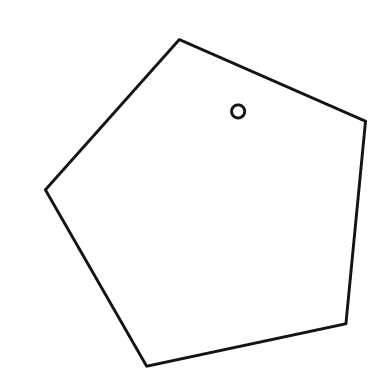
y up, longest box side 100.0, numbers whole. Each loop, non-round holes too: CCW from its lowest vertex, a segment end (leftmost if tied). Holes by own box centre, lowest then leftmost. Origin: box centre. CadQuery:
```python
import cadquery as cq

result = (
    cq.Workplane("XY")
    .moveTo(-18.0, -50.0)
    .lineTo(43.0, -37.0)
    .lineTo(49.0, 25.0)
    .lineTo(-8.0, 50.0)
    .lineTo(-49.0, 4.0)
    .close()
    .moveTo(10.0, 28.0)
    .circle(2.0)
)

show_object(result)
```